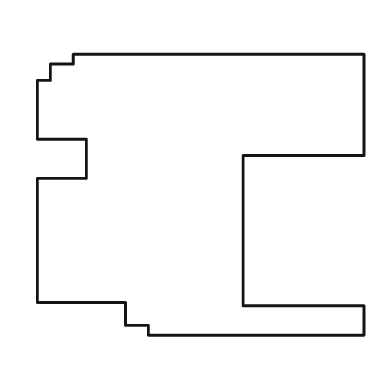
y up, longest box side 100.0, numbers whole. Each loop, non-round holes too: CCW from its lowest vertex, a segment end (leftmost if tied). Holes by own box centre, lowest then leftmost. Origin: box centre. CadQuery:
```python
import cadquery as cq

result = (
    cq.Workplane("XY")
    .moveTo(-16.0, -43.0)
    .lineTo(50.0, -43.0)
    .lineTo(50.0, -34.0)
    .lineTo(13.0, -34.0)
    .lineTo(13.0, 12.0)
    .lineTo(50.0, 12.0)
    .lineTo(50.0, 43.0)
    .lineTo(-39.0, 43.0)
    .lineTo(-39.0, 40.0)
    .lineTo(-46.0, 40.0)
    .lineTo(-46.0, 35.0)
    .lineTo(-50.0, 35.0)
    .lineTo(-50.0, 17.0)
    .lineTo(-35.0, 17.0)
    .lineTo(-35.0, 5.0)
    .lineTo(-50.0, 5.0)
    .lineTo(-50.0, -33.0)
    .lineTo(-23.0, -33.0)
    .lineTo(-23.0, -40.0)
    .lineTo(-16.0, -40.0)
    .close()
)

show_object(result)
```